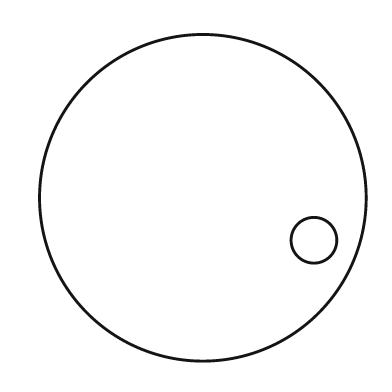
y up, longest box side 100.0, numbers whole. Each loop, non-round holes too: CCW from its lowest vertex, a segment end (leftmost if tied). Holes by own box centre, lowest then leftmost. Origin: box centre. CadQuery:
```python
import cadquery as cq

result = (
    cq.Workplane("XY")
    .moveTo(0.0, 0.0)
    .circle(50.0)
    .moveTo(34.0, -13.0)
    .circle(7.0)
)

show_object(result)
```